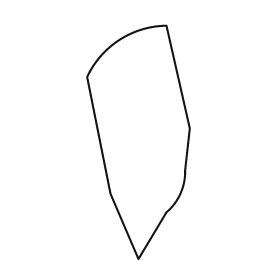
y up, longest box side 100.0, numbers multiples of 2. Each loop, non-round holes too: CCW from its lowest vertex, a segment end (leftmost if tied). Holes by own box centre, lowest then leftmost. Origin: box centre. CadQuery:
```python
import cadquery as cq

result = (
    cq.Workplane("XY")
    .moveTo(0.0, -50.0)
    .lineTo(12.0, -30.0)
    .threePointArc((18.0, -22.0), (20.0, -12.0))
    .lineTo(22.0, 6.0)
    .lineTo(12.0, 50.0)
    .threePointArc((-8.0, 44.0), (-22.0, 28.0))
    .lineTo(-12.0, -22.0)
    .close()
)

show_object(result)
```